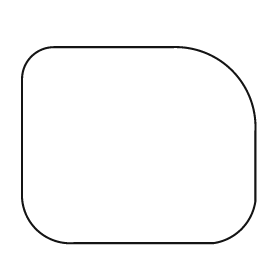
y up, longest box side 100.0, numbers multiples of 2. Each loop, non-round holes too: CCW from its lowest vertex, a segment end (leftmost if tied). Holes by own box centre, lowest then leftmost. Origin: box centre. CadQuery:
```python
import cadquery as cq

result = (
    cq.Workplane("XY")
    .moveTo(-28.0, -42.0)
    .lineTo(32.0, -42.0)
    .threePointArc((44.0, -36.0), (50.0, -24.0))
    .lineTo(50.0, 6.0)
    .threePointArc((40.0, 32.0), (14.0, 42.0))
    .lineTo(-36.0, 42.0)
    .threePointArc((-46.0, 38.0), (-50.0, 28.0))
    .lineTo(-50.0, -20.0)
    .threePointArc((-44.0, -36.0), (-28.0, -42.0))
    .close()
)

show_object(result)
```